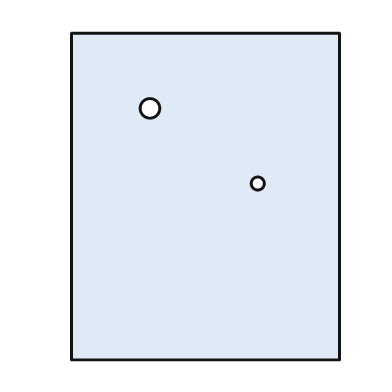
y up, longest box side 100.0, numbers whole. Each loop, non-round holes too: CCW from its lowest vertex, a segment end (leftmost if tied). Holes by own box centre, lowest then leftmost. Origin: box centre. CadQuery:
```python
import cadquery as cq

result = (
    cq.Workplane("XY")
    .moveTo(-41.0, -50.0)
    .lineTo(41.0, -50.0)
    .lineTo(41.0, 50.0)
    .lineTo(-41.0, 50.0)
    .close()
    .moveTo(16.0, 4.0)
    .circle(2.0)
    .moveTo(-17.0, 27.0)
    .circle(3.0)
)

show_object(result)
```